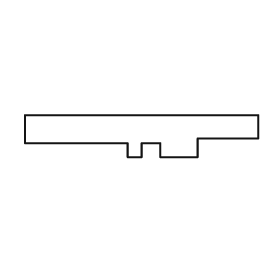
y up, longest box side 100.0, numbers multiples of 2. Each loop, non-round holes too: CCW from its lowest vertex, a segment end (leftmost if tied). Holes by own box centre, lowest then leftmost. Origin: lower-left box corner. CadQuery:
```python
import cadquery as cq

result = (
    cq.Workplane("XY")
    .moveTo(44.0, 0.0)
    .lineTo(50.0, 0.0)
    .lineTo(50.0, 6.0)
    .lineTo(58.0, 6.0)
    .lineTo(58.0, 0.0)
    .lineTo(74.0, 0.0)
    .lineTo(74.0, 8.0)
    .lineTo(100.0, 8.0)
    .lineTo(100.0, 18.0)
    .lineTo(0.0, 18.0)
    .lineTo(0.0, 6.0)
    .lineTo(44.0, 6.0)
    .close()
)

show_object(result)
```